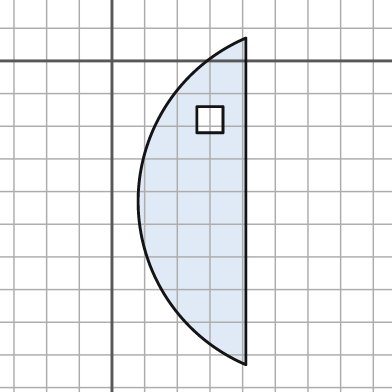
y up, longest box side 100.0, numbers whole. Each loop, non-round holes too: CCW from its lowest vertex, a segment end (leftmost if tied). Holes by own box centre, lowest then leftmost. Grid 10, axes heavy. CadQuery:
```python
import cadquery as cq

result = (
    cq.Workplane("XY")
    .moveTo(41.0, -93.0)
    .lineTo(41.0, 7.0)
    .threePointArc((8.0, -43.0), (41.0, -93.0))
    .close()
    .moveTo(26.0, -22.0)
    .lineTo(34.0, -22.0)
    .lineTo(34.0, -14.0)
    .lineTo(26.0, -14.0)
    .close()
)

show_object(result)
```